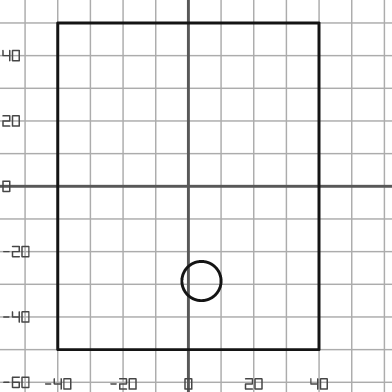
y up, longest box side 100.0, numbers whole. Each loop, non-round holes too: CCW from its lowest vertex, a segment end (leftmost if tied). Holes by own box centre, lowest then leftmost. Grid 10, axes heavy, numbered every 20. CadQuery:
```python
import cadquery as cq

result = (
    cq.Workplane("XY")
    .moveTo(-40.0, -50.0)
    .lineTo(40.0, -50.0)
    .lineTo(40.0, 50.0)
    .lineTo(-40.0, 50.0)
    .close()
    .moveTo(4.0, -29.0)
    .circle(6.0)
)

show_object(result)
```